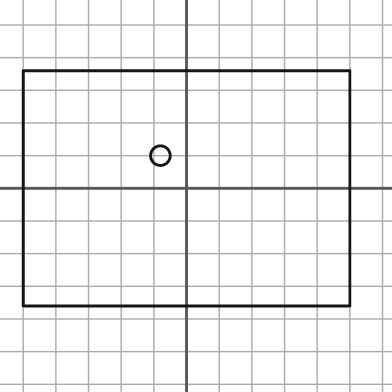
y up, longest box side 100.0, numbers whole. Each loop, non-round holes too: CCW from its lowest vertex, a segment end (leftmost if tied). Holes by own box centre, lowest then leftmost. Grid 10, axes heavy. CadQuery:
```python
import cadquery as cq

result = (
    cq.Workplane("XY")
    .moveTo(-50.0, -36.0)
    .lineTo(50.0, -36.0)
    .lineTo(50.0, 36.0)
    .lineTo(-50.0, 36.0)
    .close()
    .moveTo(-8.0, 10.0)
    .circle(3.0)
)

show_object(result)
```